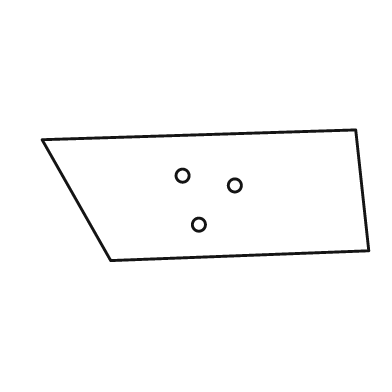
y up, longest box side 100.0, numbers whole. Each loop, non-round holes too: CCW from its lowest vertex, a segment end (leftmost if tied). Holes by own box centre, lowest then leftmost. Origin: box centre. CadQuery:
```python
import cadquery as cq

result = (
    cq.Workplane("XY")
    .moveTo(-29.0, -20.0)
    .lineTo(50.0, -17.0)
    .lineTo(46.0, 20.0)
    .lineTo(-50.0, 17.0)
    .close()
    .moveTo(-2.0, -9.0)
    .circle(2.0)
    .moveTo(9.0, 3.0)
    .circle(2.0)
    .moveTo(-7.0, 6.0)
    .circle(2.0)
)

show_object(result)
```